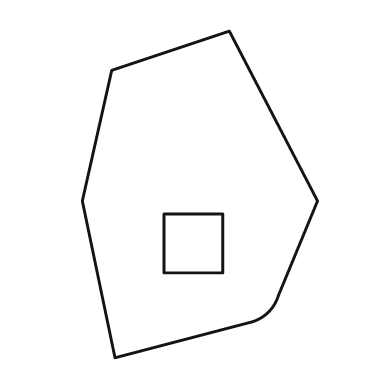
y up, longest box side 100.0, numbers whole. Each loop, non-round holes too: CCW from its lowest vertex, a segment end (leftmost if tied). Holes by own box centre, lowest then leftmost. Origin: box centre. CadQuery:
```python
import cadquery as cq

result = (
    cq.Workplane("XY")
    .moveTo(-26.0, -50.0)
    .lineTo(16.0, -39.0)
    .threePointArc((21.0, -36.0), (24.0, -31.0))
    .lineTo(36.0, -2.0)
    .lineTo(9.0, 50.0)
    .lineTo(-27.0, 38.0)
    .lineTo(-36.0, -2.0)
    .close()
    .moveTo(-11.0, -24.0)
    .lineTo(7.0, -24.0)
    .lineTo(7.0, -6.0)
    .lineTo(-11.0, -6.0)
    .close()
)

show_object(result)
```